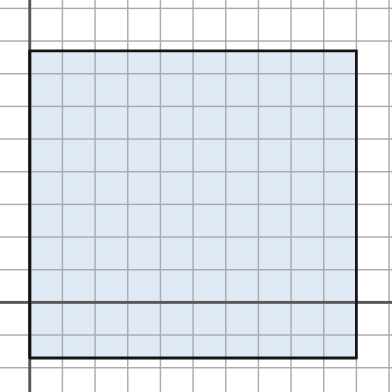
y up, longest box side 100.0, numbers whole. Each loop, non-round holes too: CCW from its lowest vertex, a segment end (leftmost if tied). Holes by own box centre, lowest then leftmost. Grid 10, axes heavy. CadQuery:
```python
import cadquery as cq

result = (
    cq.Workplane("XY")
    .moveTo(0.0, -17.0)
    .lineTo(100.0, -17.0)
    .lineTo(100.0, 77.0)
    .lineTo(0.0, 77.0)
    .close()
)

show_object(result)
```